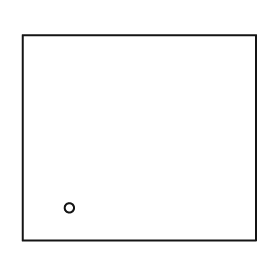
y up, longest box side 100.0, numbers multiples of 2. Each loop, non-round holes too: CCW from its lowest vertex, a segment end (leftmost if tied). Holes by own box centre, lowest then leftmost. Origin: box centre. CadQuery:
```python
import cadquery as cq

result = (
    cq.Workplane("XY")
    .moveTo(-50.0, -44.0)
    .lineTo(50.0, -44.0)
    .lineTo(50.0, 44.0)
    .lineTo(-50.0, 44.0)
    .close()
    .moveTo(-30.0, -30.0)
    .circle(2.0)
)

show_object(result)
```